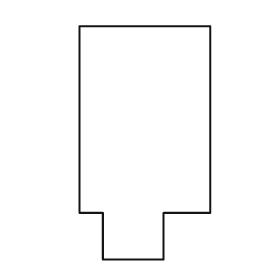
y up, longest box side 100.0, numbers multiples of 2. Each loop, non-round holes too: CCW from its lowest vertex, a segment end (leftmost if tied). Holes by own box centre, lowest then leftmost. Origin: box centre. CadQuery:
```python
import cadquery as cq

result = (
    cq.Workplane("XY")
    .moveTo(-18.0, -50.0)
    .lineTo(8.0, -50.0)
    .lineTo(8.0, -30.0)
    .lineTo(28.0, -30.0)
    .lineTo(28.0, 50.0)
    .lineTo(-28.0, 50.0)
    .lineTo(-28.0, -30.0)
    .lineTo(-18.0, -30.0)
    .close()
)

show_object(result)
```